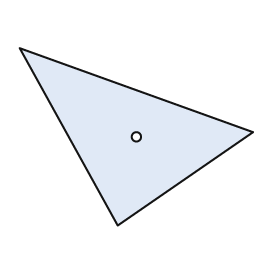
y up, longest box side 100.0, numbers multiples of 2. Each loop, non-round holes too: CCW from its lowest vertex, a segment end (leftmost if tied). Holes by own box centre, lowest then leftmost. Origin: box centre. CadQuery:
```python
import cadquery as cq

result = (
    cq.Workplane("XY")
    .moveTo(-8.0, -38.0)
    .lineTo(50.0, 2.0)
    .lineTo(-50.0, 38.0)
    .close()
    .moveTo(0.0, 0.0)
    .circle(2.0)
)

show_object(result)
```